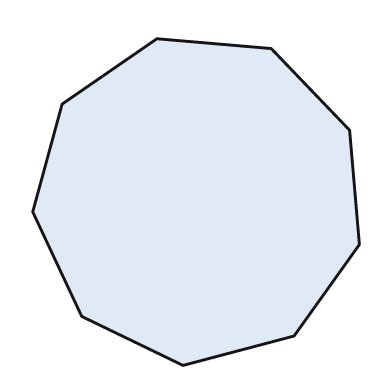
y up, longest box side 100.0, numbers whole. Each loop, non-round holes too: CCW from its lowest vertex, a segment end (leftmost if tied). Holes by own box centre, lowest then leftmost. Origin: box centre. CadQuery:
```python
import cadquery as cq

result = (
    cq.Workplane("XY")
    .moveTo(-4.0, -50.0)
    .lineTo(30.0, -41.0)
    .lineTo(50.0, -13.0)
    .lineTo(47.0, 22.0)
    .lineTo(23.0, 47.0)
    .lineTo(-12.0, 50.0)
    .lineTo(-41.0, 30.0)
    .lineTo(-50.0, -3.0)
    .lineTo(-35.0, -35.0)
    .close()
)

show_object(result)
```